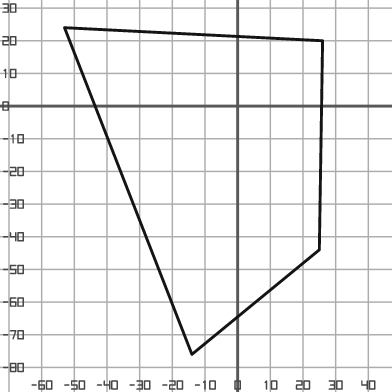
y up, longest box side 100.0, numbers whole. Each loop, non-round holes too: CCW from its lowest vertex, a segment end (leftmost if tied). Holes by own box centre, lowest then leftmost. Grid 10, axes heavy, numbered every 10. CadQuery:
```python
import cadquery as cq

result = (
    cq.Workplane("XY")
    .moveTo(-14.0, -76.0)
    .lineTo(25.0, -44.0)
    .lineTo(26.0, 20.0)
    .lineTo(-53.0, 24.0)
    .close()
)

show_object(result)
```